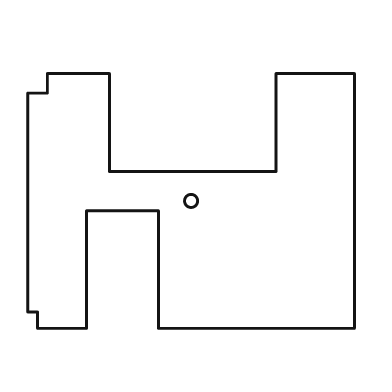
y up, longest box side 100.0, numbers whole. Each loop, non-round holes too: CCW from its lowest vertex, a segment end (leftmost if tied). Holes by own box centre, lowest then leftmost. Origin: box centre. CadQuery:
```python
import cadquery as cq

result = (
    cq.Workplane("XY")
    .moveTo(-47.0, -39.0)
    .lineTo(-32.0, -39.0)
    .lineTo(-32.0, -3.0)
    .lineTo(-10.0, -3.0)
    .lineTo(-10.0, -39.0)
    .lineTo(50.0, -39.0)
    .lineTo(50.0, 39.0)
    .lineTo(26.0, 39.0)
    .lineTo(26.0, 9.0)
    .lineTo(-25.0, 9.0)
    .lineTo(-25.0, 39.0)
    .lineTo(-44.0, 39.0)
    .lineTo(-44.0, 33.0)
    .lineTo(-50.0, 33.0)
    .lineTo(-50.0, -34.0)
    .lineTo(-47.0, -34.0)
    .close()
    .moveTo(0.0, 0.0)
    .circle(2.0)
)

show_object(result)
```